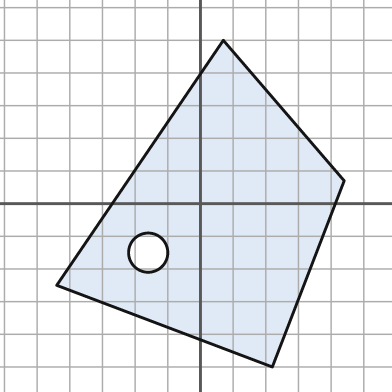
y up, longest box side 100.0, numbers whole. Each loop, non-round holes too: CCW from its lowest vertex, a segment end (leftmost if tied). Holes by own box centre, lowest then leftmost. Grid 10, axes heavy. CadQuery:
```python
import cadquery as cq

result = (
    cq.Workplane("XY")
    .moveTo(22.0, -50.0)
    .lineTo(44.0, 7.0)
    .lineTo(7.0, 50.0)
    .lineTo(-44.0, -25.0)
    .close()
    .moveTo(-16.0, -15.0)
    .circle(6.0)
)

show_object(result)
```